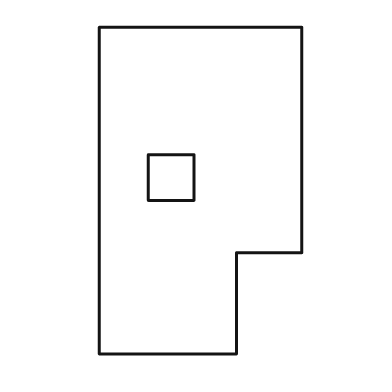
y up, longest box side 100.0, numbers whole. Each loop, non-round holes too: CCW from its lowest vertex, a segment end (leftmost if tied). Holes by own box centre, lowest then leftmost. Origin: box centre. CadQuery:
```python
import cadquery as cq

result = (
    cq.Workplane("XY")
    .moveTo(-31.0, -50.0)
    .lineTo(11.0, -50.0)
    .lineTo(11.0, -19.0)
    .lineTo(31.0, -19.0)
    .lineTo(31.0, 50.0)
    .lineTo(-31.0, 50.0)
    .close()
    .moveTo(-16.0, -3.0)
    .lineTo(-2.0, -3.0)
    .lineTo(-2.0, 11.0)
    .lineTo(-16.0, 11.0)
    .close()
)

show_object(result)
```